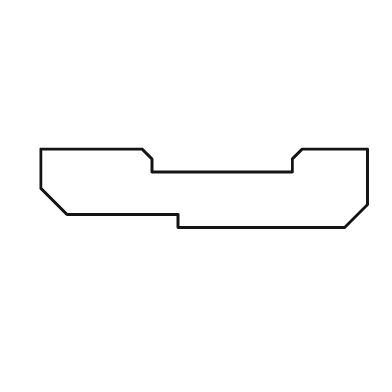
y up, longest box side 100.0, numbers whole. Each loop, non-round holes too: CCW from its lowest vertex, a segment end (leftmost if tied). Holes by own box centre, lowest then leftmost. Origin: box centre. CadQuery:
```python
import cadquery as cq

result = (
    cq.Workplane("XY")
    .moveTo(-8.0, -12.0)
    .lineTo(43.0, -12.0)
    .lineTo(50.0, -5.0)
    .lineTo(50.0, 12.0)
    .lineTo(30.0, 12.0)
    .lineTo(27.0, 9.0)
    .lineTo(27.0, 5.0)
    .lineTo(-16.0, 5.0)
    .lineTo(-16.0, 9.0)
    .lineTo(-19.0, 12.0)
    .lineTo(-50.0, 12.0)
    .lineTo(-50.0, 0.0)
    .lineTo(-42.0, -8.0)
    .lineTo(-8.0, -8.0)
    .close()
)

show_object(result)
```